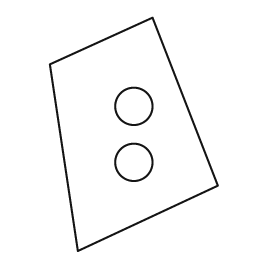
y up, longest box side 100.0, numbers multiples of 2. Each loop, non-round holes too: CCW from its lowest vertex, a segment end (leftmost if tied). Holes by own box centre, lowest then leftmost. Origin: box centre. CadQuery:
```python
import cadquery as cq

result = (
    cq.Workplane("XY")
    .moveTo(-24.0, -50.0)
    .lineTo(36.0, -22.0)
    .lineTo(8.0, 50.0)
    .lineTo(-36.0, 30.0)
    .close()
    .moveTo(0.0, -12.0)
    .circle(8.0)
    .moveTo(0.0, 12.0)
    .circle(8.0)
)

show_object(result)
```